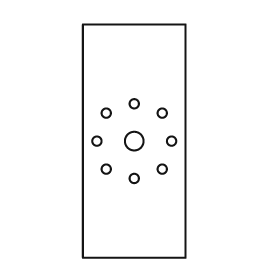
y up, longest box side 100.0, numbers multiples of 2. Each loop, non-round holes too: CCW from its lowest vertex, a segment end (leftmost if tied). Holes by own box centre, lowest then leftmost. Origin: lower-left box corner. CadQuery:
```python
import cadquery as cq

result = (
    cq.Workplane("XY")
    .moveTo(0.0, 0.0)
    .lineTo(44.0, 0.0)
    .lineTo(44.0, 100.0)
    .lineTo(0.0, 100.0)
    .close()
    .moveTo(22.0, 34.0)
    .circle(2.0)
    .moveTo(10.0, 38.0)
    .circle(2.0)
    .moveTo(34.0, 38.0)
    .circle(2.0)
    .moveTo(6.0, 50.0)
    .circle(2.0)
    .moveTo(22.0, 50.0)
    .circle(4.0)
    .moveTo(38.0, 50.0)
    .circle(2.0)
    .moveTo(10.0, 62.0)
    .circle(2.0)
    .moveTo(34.0, 62.0)
    .circle(2.0)
    .moveTo(22.0, 66.0)
    .circle(2.0)
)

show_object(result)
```